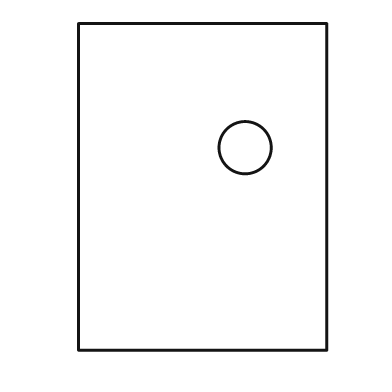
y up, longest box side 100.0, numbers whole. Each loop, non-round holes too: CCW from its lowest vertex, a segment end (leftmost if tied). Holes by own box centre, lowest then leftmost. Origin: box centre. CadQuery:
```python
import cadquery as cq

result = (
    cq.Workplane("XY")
    .moveTo(-38.0, -50.0)
    .lineTo(38.0, -50.0)
    .lineTo(38.0, 50.0)
    .lineTo(-38.0, 50.0)
    .close()
    .moveTo(13.0, 12.0)
    .circle(8.0)
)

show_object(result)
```